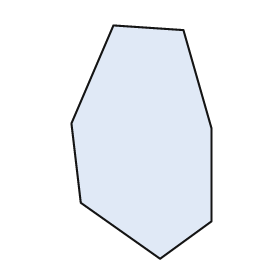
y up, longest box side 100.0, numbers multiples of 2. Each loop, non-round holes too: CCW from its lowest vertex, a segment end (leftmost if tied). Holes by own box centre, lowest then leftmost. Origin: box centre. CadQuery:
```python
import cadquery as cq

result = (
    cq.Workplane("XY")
    .moveTo(8.0, -50.0)
    .lineTo(30.0, -34.0)
    .lineTo(30.0, 6.0)
    .lineTo(18.0, 48.0)
    .lineTo(-12.0, 50.0)
    .lineTo(-30.0, 8.0)
    .lineTo(-26.0, -26.0)
    .close()
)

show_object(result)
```